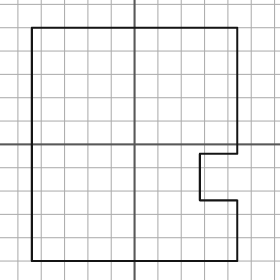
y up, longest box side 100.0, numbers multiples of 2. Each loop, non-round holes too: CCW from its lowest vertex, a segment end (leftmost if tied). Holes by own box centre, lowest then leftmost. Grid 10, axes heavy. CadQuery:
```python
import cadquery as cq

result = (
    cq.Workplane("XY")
    .moveTo(-44.0, -50.0)
    .lineTo(44.0, -50.0)
    .lineTo(44.0, -24.0)
    .lineTo(28.0, -24.0)
    .lineTo(28.0, -4.0)
    .lineTo(44.0, -4.0)
    .lineTo(44.0, 50.0)
    .lineTo(-44.0, 50.0)
    .close()
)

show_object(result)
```